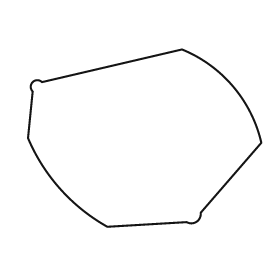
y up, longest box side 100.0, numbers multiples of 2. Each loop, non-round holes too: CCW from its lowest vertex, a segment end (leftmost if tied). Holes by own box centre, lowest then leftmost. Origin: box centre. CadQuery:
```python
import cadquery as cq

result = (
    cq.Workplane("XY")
    .moveTo(-16.0, -38.0)
    .lineTo(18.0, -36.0)
    .threePointArc((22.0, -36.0), (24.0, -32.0))
    .lineTo(50.0, -2.0)
    .threePointArc((38.0, 22.0), (16.0, 38.0))
    .lineTo(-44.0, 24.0)
    .threePointArc((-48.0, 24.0), (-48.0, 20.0))
    .lineTo(-50.0, 0.0)
    .threePointArc((-36.0, -22.0), (-16.0, -38.0))
    .close()
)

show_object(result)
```